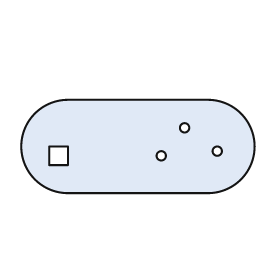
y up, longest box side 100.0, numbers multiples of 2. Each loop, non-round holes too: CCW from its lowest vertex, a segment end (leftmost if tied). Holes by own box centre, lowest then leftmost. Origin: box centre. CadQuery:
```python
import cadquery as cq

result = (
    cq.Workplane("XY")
    .moveTo(-30.0, -20.0)
    .lineTo(30.0, -20.0)
    .threePointArc((50.0, 0.0), (30.0, 20.0))
    .lineTo(-30.0, 20.0)
    .threePointArc((-50.0, 0.0), (-30.0, -20.0))
    .close()
    .moveTo(-38.0, -8.0)
    .lineTo(-30.0, -8.0)
    .lineTo(-30.0, 0.0)
    .lineTo(-38.0, 0.0)
    .close()
    .moveTo(10.0, -4.0)
    .circle(2.0)
    .moveTo(34.0, -2.0)
    .circle(2.0)
    .moveTo(20.0, 8.0)
    .circle(2.0)
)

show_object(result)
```